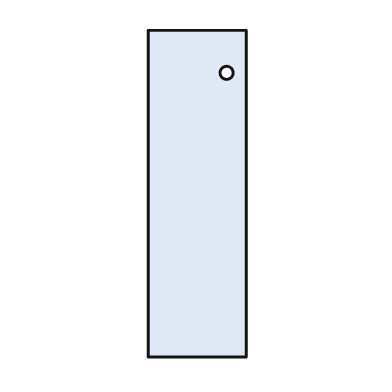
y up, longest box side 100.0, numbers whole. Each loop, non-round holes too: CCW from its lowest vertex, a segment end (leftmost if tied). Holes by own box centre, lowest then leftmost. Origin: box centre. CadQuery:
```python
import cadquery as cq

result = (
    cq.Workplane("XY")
    .moveTo(-15.0, -50.0)
    .lineTo(15.0, -50.0)
    .lineTo(15.0, 50.0)
    .lineTo(-15.0, 50.0)
    .close()
    .moveTo(9.0, 37.0)
    .circle(2.0)
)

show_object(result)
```